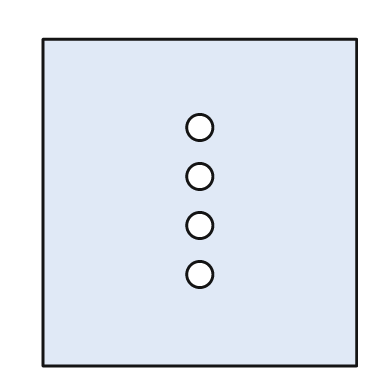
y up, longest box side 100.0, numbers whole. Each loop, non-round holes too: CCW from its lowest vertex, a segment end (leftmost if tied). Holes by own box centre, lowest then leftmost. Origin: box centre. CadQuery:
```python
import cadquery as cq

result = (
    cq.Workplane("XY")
    .moveTo(-48.0, -50.0)
    .lineTo(48.0, -50.0)
    .lineTo(48.0, 50.0)
    .lineTo(-48.0, 50.0)
    .close()
    .moveTo(0.0, -22.0)
    .circle(4.0)
    .moveTo(0.0, -7.0)
    .circle(4.0)
    .moveTo(0.0, 8.0)
    .circle(4.0)
    .moveTo(0.0, 23.0)
    .circle(4.0)
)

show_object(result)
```